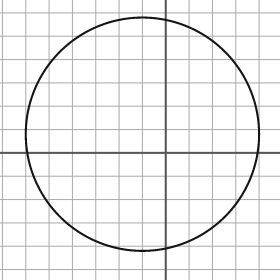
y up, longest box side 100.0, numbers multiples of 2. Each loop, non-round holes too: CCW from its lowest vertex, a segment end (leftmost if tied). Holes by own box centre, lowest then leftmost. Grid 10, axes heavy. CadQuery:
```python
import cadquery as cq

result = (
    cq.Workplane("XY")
    .moveTo(-10.0, 8.0)
    .circle(50.0)
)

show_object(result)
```